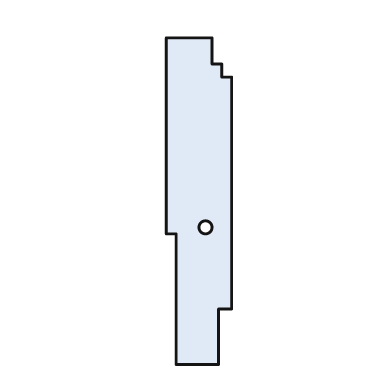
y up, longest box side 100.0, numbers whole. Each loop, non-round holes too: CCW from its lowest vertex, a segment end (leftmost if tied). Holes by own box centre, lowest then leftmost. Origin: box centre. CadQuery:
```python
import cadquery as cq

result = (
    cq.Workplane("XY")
    .moveTo(-7.0, -50.0)
    .lineTo(6.0, -50.0)
    .lineTo(6.0, -33.0)
    .lineTo(10.0, -33.0)
    .lineTo(10.0, 38.0)
    .lineTo(7.0, 38.0)
    .lineTo(7.0, 42.0)
    .lineTo(4.0, 42.0)
    .lineTo(4.0, 50.0)
    .lineTo(-10.0, 50.0)
    .lineTo(-10.0, -10.0)
    .lineTo(-7.0, -10.0)
    .close()
    .moveTo(2.0, -8.0)
    .circle(2.0)
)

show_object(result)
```